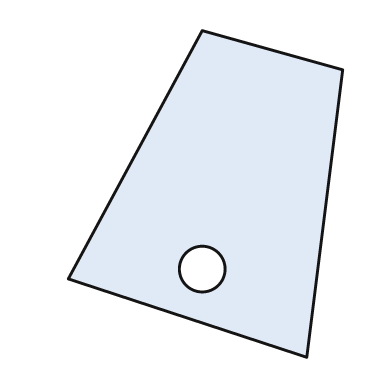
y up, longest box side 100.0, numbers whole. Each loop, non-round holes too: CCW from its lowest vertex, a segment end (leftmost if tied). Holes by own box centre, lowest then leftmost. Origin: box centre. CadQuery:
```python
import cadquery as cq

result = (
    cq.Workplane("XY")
    .moveTo(31.0, -50.0)
    .lineTo(42.0, 38.0)
    .lineTo(-1.0, 50.0)
    .lineTo(-42.0, -26.0)
    .close()
    .moveTo(-1.0, -23.0)
    .circle(7.0)
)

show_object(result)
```